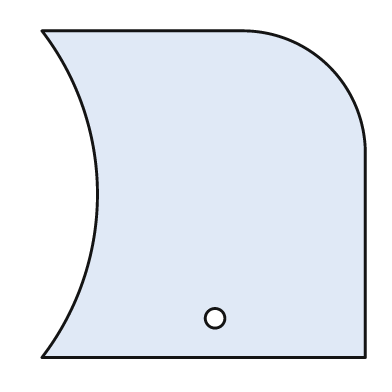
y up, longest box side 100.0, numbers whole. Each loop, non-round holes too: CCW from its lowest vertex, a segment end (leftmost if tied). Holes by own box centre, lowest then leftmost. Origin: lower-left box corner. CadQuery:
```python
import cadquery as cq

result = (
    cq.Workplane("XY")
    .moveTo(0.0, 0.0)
    .lineTo(99.0, 0.0)
    .lineTo(99.0, 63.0)
    .threePointArc((88.0, 89.0), (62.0, 100.0))
    .lineTo(0.0, 100.0)
    .threePointArc((17.0, 50.0), (0.0, 0.0))
    .close()
    .moveTo(53.0, 12.0)
    .circle(3.0)
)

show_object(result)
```